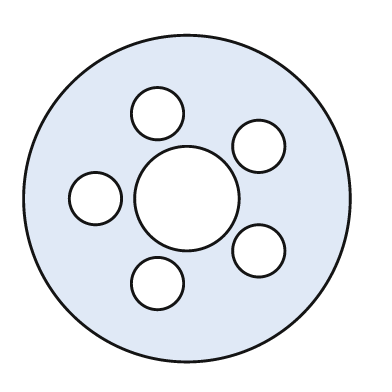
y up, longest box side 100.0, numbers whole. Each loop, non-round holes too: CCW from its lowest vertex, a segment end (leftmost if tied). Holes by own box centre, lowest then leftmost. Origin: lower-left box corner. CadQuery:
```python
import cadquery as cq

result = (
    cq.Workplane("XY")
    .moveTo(50.0, 50.0)
    .circle(50.0)
    .moveTo(41.0, 24.0)
    .circle(8.0)
    .moveTo(72.0, 34.0)
    .circle(8.0)
    .moveTo(22.0, 50.0)
    .circle(8.0)
    .moveTo(50.0, 50.0)
    .circle(16.0)
    .moveTo(72.0, 66.0)
    .circle(8.0)
    .moveTo(41.0, 76.0)
    .circle(8.0)
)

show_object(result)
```